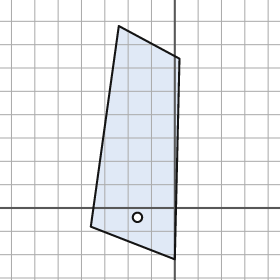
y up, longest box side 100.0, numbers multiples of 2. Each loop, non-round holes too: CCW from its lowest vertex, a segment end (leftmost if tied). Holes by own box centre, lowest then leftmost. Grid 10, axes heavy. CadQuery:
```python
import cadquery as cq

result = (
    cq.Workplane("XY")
    .moveTo(0.0, -22.0)
    .lineTo(2.0, 64.0)
    .lineTo(-24.0, 78.0)
    .lineTo(-36.0, -8.0)
    .close()
    .moveTo(-16.0, -4.0)
    .circle(2.0)
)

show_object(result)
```